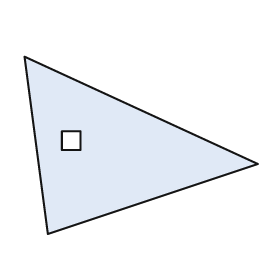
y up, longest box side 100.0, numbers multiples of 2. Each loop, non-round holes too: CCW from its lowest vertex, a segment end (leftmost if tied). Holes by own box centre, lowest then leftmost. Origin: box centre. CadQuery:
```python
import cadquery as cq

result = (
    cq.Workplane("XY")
    .moveTo(-40.0, -38.0)
    .lineTo(50.0, -8.0)
    .lineTo(-50.0, 38.0)
    .close()
    .moveTo(-34.0, -2.0)
    .lineTo(-26.0, -2.0)
    .lineTo(-26.0, 6.0)
    .lineTo(-34.0, 6.0)
    .close()
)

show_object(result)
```